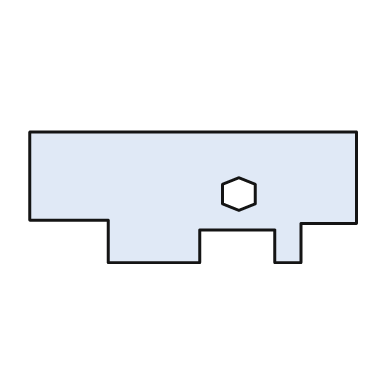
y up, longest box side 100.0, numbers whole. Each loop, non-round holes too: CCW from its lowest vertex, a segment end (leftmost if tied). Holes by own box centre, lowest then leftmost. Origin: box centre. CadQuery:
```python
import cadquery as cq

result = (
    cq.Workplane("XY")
    .moveTo(-26.0, -20.0)
    .lineTo(2.0, -20.0)
    .lineTo(2.0, -10.0)
    .lineTo(25.0, -10.0)
    .lineTo(25.0, -20.0)
    .lineTo(33.0, -20.0)
    .lineTo(33.0, -8.0)
    .lineTo(50.0, -8.0)
    .lineTo(50.0, 20.0)
    .lineTo(-50.0, 20.0)
    .lineTo(-50.0, -7.0)
    .lineTo(-26.0, -7.0)
    .close()
    .moveTo(14.0, -4.0)
    .lineTo(19.0, -2.0)
    .lineTo(19.0, 4.0)
    .lineTo(14.0, 6.0)
    .lineTo(9.0, 4.0)
    .lineTo(9.0, -2.0)
    .close()
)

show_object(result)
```